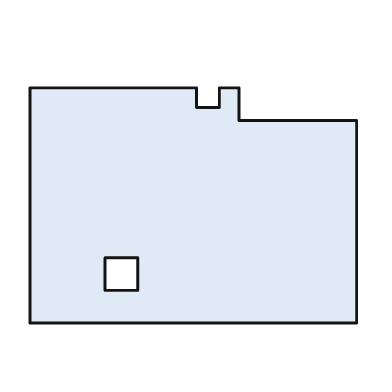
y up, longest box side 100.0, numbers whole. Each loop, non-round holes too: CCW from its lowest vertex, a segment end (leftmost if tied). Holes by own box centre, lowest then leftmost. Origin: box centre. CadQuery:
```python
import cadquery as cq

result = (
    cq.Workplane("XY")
    .moveTo(-50.0, -36.0)
    .lineTo(50.0, -36.0)
    .lineTo(50.0, 26.0)
    .lineTo(14.0, 26.0)
    .lineTo(14.0, 36.0)
    .lineTo(8.0, 36.0)
    .lineTo(8.0, 30.0)
    .lineTo(1.0, 30.0)
    .lineTo(1.0, 36.0)
    .lineTo(-50.0, 36.0)
    .close()
    .moveTo(-27.0, -26.0)
    .lineTo(-17.0, -26.0)
    .lineTo(-17.0, -16.0)
    .lineTo(-27.0, -16.0)
    .close()
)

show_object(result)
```